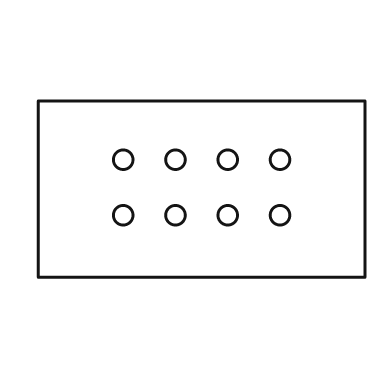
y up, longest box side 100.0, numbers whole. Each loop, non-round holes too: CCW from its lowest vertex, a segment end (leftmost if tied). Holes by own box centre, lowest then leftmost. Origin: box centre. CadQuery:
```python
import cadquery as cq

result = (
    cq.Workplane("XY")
    .moveTo(-50.0, -27.0)
    .lineTo(50.0, -27.0)
    .lineTo(50.0, 27.0)
    .lineTo(-50.0, 27.0)
    .close()
    .moveTo(-24.0, -8.0)
    .circle(3.0)
    .moveTo(-8.0, -8.0)
    .circle(3.0)
    .moveTo(8.0, -8.0)
    .circle(3.0)
    .moveTo(24.0, -8.0)
    .circle(3.0)
    .moveTo(-24.0, 9.0)
    .circle(3.0)
    .moveTo(-8.0, 9.0)
    .circle(3.0)
    .moveTo(8.0, 9.0)
    .circle(3.0)
    .moveTo(24.0, 9.0)
    .circle(3.0)
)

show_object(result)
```